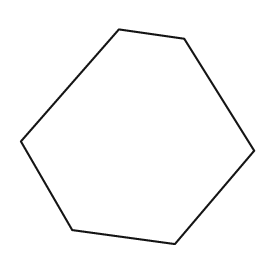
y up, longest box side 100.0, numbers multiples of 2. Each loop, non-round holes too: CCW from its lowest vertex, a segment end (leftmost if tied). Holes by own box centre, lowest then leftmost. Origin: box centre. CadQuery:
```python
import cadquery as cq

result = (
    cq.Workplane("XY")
    .moveTo(16.0, -46.0)
    .lineTo(50.0, -6.0)
    .lineTo(20.0, 42.0)
    .lineTo(-8.0, 46.0)
    .lineTo(-50.0, -2.0)
    .lineTo(-28.0, -40.0)
    .close()
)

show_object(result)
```